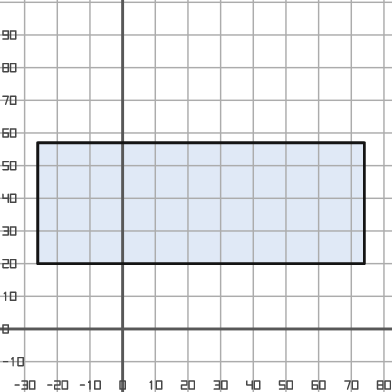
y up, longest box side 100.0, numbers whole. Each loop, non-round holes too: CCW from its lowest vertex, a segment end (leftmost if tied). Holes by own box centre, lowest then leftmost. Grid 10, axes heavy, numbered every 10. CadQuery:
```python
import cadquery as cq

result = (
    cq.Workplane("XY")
    .moveTo(-26.0, 20.0)
    .lineTo(74.0, 20.0)
    .lineTo(74.0, 57.0)
    .lineTo(-26.0, 57.0)
    .close()
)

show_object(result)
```